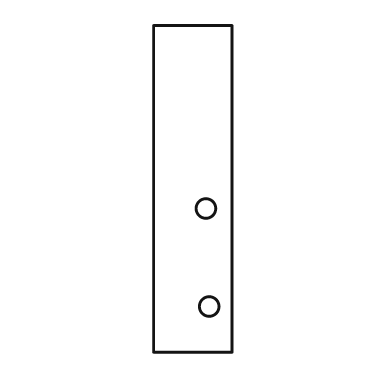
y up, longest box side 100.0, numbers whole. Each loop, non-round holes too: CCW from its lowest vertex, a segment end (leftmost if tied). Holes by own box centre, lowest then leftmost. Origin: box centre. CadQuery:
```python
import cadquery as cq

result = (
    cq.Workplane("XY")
    .moveTo(-12.0, -50.0)
    .lineTo(12.0, -50.0)
    .lineTo(12.0, 50.0)
    .lineTo(-12.0, 50.0)
    .close()
    .moveTo(5.0, -36.0)
    .circle(3.0)
    .moveTo(4.0, -6.0)
    .circle(3.0)
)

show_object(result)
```